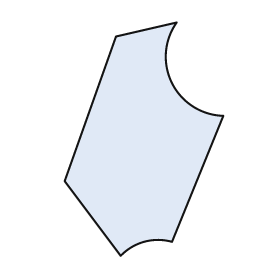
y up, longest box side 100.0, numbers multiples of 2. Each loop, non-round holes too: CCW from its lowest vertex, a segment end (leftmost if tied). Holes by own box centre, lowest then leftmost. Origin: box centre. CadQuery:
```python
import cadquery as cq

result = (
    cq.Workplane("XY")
    .moveTo(-10.0, -50.0)
    .threePointArc((0.0, -44.0), (12.0, -44.0))
    .lineTo(34.0, 10.0)
    .threePointArc((12.0, 24.0), (14.0, 50.0))
    .lineTo(-12.0, 44.0)
    .lineTo(-34.0, -18.0)
    .close()
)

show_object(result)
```